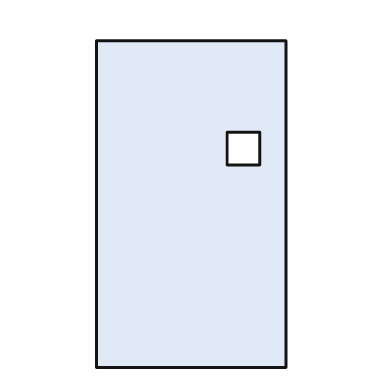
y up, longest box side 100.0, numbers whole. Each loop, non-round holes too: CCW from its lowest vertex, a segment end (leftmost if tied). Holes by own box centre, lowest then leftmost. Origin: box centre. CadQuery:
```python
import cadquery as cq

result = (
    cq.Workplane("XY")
    .moveTo(-29.0, -50.0)
    .lineTo(29.0, -50.0)
    .lineTo(29.0, 50.0)
    .lineTo(-29.0, 50.0)
    .close()
    .moveTo(11.0, 12.0)
    .lineTo(21.0, 12.0)
    .lineTo(21.0, 22.0)
    .lineTo(11.0, 22.0)
    .close()
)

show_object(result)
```